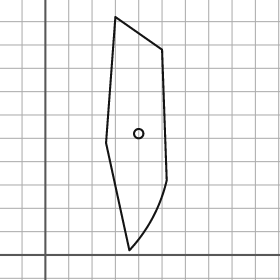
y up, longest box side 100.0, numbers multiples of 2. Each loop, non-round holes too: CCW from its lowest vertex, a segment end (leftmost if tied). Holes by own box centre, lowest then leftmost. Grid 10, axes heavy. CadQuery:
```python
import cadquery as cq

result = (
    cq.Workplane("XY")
    .moveTo(36.0, 2.0)
    .threePointArc((46.0, 16.0), (52.0, 32.0))
    .lineTo(50.0, 88.0)
    .lineTo(30.0, 102.0)
    .lineTo(26.0, 48.0)
    .close()
    .moveTo(40.0, 52.0)
    .circle(2.0)
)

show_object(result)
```